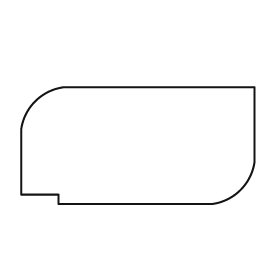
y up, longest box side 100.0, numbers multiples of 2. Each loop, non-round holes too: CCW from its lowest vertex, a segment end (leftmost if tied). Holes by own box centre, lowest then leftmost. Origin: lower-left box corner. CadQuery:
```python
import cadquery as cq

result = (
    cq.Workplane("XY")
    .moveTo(16.0, 0.0)
    .lineTo(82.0, 0.0)
    .threePointArc((94.0, 6.0), (100.0, 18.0))
    .lineTo(100.0, 50.0)
    .lineTo(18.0, 50.0)
    .threePointArc((6.0, 44.0), (0.0, 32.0))
    .lineTo(0.0, 4.0)
    .lineTo(16.0, 4.0)
    .close()
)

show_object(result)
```